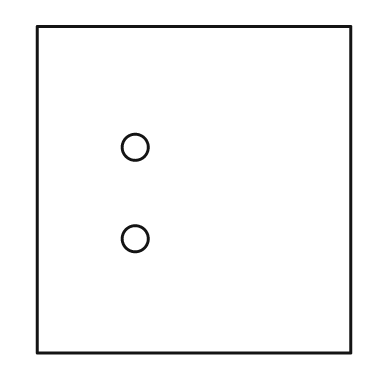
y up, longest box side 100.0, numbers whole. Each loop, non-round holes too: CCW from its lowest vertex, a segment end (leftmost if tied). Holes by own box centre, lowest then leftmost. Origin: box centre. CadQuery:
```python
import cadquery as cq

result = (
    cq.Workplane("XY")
    .moveTo(-48.0, -50.0)
    .lineTo(48.0, -50.0)
    .lineTo(48.0, 50.0)
    .lineTo(-48.0, 50.0)
    .close()
    .moveTo(-18.0, -15.0)
    .circle(4.0)
    .moveTo(-18.0, 13.0)
    .circle(4.0)
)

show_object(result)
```